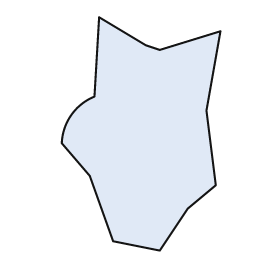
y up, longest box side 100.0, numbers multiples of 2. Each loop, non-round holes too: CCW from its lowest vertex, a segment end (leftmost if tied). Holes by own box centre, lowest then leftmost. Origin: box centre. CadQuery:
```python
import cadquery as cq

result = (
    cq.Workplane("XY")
    .moveTo(8.0, -50.0)
    .lineTo(20.0, -32.0)
    .lineTo(32.0, -22.0)
    .lineTo(28.0, 10.0)
    .lineTo(34.0, 44.0)
    .lineTo(8.0, 36.0)
    .lineTo(2.0, 38.0)
    .lineTo(-18.0, 50.0)
    .lineTo(-20.0, 16.0)
    .threePointArc((-30.0, 8.0), (-34.0, -4.0))
    .lineTo(-22.0, -18.0)
    .lineTo(-12.0, -46.0)
    .close()
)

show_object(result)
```